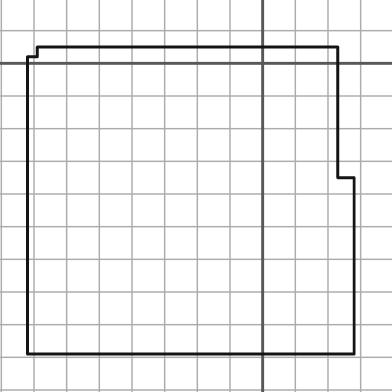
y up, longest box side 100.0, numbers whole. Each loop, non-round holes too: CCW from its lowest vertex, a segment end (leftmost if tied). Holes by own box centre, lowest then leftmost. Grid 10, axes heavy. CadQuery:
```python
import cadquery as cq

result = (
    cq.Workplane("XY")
    .moveTo(-72.0, -89.0)
    .lineTo(28.0, -89.0)
    .lineTo(28.0, -35.0)
    .lineTo(23.0, -35.0)
    .lineTo(23.0, 5.0)
    .lineTo(-69.0, 5.0)
    .lineTo(-69.0, 2.0)
    .lineTo(-72.0, 2.0)
    .close()
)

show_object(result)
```